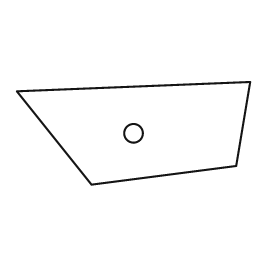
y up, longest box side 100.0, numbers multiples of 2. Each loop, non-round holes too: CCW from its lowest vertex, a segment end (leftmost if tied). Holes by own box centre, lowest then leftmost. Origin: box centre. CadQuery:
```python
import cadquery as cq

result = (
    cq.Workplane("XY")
    .moveTo(-18.0, -22.0)
    .lineTo(44.0, -14.0)
    .lineTo(50.0, 22.0)
    .lineTo(-50.0, 18.0)
    .close()
    .moveTo(0.0, 0.0)
    .circle(4.0)
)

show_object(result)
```